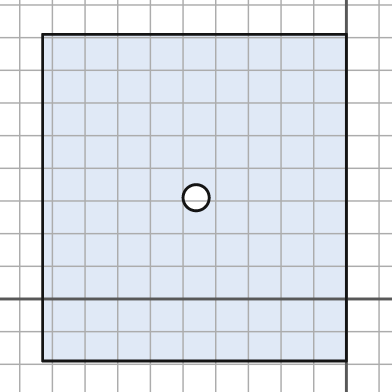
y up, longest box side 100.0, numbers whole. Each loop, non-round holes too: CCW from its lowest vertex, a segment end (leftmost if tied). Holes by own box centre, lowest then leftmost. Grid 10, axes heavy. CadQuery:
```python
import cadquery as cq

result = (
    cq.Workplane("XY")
    .moveTo(-93.0, -19.0)
    .lineTo(0.0, -19.0)
    .lineTo(0.0, 81.0)
    .lineTo(-93.0, 81.0)
    .close()
    .moveTo(-46.0, 31.0)
    .circle(4.0)
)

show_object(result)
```